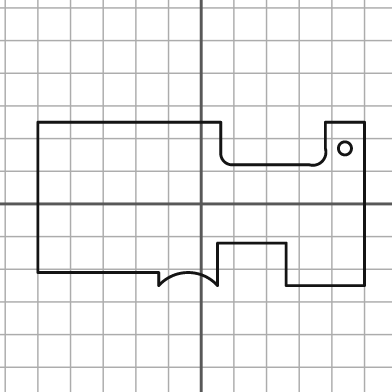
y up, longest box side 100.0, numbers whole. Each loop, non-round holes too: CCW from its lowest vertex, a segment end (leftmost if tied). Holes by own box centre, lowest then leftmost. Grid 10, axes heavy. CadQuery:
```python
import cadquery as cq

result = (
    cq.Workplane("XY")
    .moveTo(-13.0, -25.0)
    .threePointArc((-4.0, -21.0), (5.0, -25.0))
    .lineTo(5.0, -12.0)
    .lineTo(26.0, -12.0)
    .lineTo(26.0, -25.0)
    .lineTo(50.0, -25.0)
    .lineTo(50.0, 25.0)
    .lineTo(38.0, 25.0)
    .lineTo(38.0, 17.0)
    .threePointArc((37.0, 13.0), (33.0, 12.0))
    .lineTo(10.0, 12.0)
    .threePointArc((7.0, 13.0), (6.0, 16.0))
    .lineTo(6.0, 25.0)
    .lineTo(-50.0, 25.0)
    .lineTo(-50.0, -21.0)
    .lineTo(-13.0, -21.0)
    .close()
    .moveTo(44.0, 17.0)
    .circle(2.0)
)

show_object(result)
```